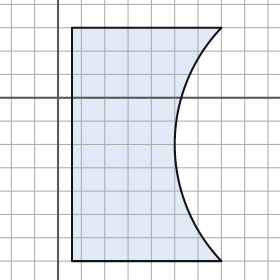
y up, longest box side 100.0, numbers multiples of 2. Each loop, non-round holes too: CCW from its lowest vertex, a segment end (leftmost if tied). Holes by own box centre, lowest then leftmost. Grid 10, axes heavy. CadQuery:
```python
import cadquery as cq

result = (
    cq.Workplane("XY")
    .moveTo(6.0, -70.0)
    .lineTo(70.0, -70.0)
    .threePointArc((50.0, -20.0), (70.0, 30.0))
    .lineTo(6.0, 30.0)
    .close()
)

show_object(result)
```